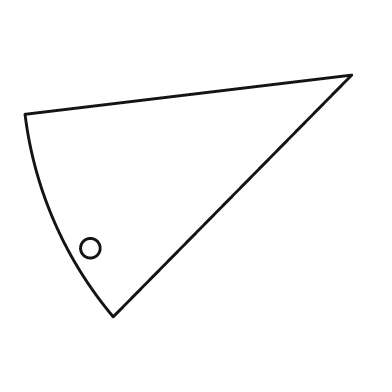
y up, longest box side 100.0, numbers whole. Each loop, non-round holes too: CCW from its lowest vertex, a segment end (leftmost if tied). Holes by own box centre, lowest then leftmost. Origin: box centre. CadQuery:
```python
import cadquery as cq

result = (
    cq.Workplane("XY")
    .moveTo(-23.0, -37.0)
    .lineTo(50.0, 37.0)
    .lineTo(-50.0, 25.0)
    .threePointArc((-41.0, -8.0), (-23.0, -37.0))
    .close()
    .moveTo(-30.0, -16.0)
    .circle(3.0)
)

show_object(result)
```